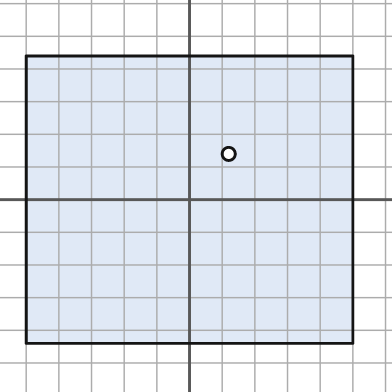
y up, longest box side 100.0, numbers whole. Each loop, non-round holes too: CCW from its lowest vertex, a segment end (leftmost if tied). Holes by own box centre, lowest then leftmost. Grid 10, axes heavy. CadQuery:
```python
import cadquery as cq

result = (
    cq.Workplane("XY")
    .moveTo(-50.0, -44.0)
    .lineTo(50.0, -44.0)
    .lineTo(50.0, 44.0)
    .lineTo(-50.0, 44.0)
    .close()
    .moveTo(12.0, 14.0)
    .circle(2.0)
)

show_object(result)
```